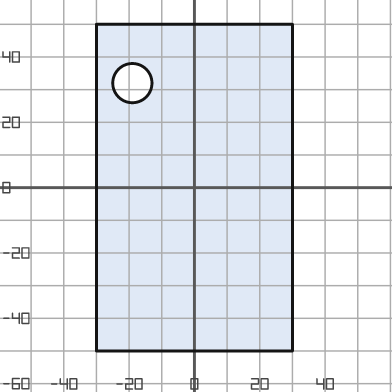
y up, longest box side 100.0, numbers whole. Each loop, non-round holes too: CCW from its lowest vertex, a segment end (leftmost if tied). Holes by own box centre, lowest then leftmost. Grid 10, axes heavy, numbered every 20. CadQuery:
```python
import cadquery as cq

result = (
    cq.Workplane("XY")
    .moveTo(-30.0, -50.0)
    .lineTo(30.0, -50.0)
    .lineTo(30.0, 50.0)
    .lineTo(-30.0, 50.0)
    .close()
    .moveTo(-19.0, 32.0)
    .circle(6.0)
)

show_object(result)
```